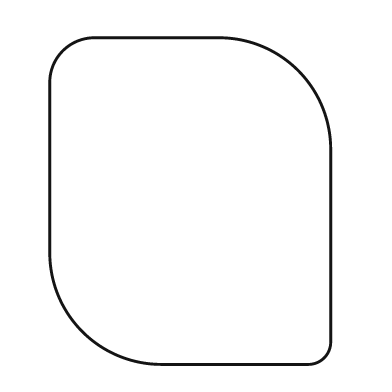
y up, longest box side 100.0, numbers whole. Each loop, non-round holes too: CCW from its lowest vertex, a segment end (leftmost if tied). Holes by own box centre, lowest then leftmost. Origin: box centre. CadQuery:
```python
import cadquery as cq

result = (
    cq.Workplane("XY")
    .moveTo(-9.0, -50.0)
    .lineTo(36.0, -50.0)
    .threePointArc((41.0, -48.0), (43.0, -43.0))
    .lineTo(43.0, 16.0)
    .threePointArc((33.0, 40.0), (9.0, 50.0))
    .lineTo(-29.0, 50.0)
    .threePointArc((-39.0, 46.0), (-43.0, 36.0))
    .lineTo(-43.0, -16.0)
    .threePointArc((-33.0, -40.0), (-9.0, -50.0))
    .close()
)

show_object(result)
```